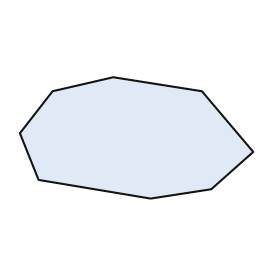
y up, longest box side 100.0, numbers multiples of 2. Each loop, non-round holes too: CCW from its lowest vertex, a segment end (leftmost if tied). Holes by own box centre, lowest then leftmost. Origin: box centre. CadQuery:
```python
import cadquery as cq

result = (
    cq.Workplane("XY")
    .moveTo(6.0, -26.0)
    .lineTo(32.0, -22.0)
    .lineTo(50.0, -6.0)
    .lineTo(28.0, 20.0)
    .lineTo(-10.0, 26.0)
    .lineTo(-36.0, 20.0)
    .lineTo(-50.0, 2.0)
    .lineTo(-42.0, -18.0)
    .close()
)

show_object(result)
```